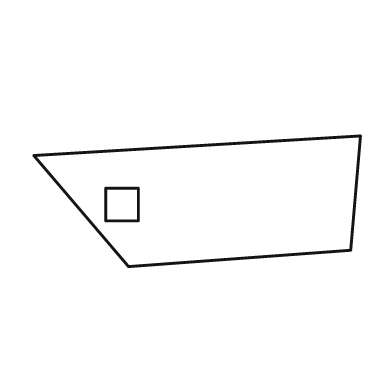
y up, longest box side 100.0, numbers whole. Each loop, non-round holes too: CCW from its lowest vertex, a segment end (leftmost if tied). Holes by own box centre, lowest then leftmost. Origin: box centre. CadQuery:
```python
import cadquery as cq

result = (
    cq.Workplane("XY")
    .moveTo(-21.0, -20.0)
    .lineTo(47.0, -15.0)
    .lineTo(50.0, 20.0)
    .lineTo(-50.0, 14.0)
    .close()
    .moveTo(-28.0, -6.0)
    .lineTo(-18.0, -6.0)
    .lineTo(-18.0, 4.0)
    .lineTo(-28.0, 4.0)
    .close()
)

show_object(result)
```